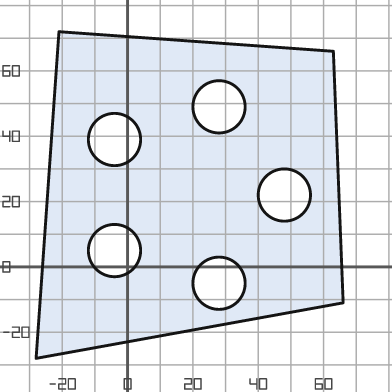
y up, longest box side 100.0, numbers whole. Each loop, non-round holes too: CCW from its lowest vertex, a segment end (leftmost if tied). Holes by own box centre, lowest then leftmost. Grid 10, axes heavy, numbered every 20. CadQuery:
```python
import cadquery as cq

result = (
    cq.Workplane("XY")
    .moveTo(-28.0, -28.0)
    .lineTo(66.0, -11.0)
    .lineTo(63.0, 66.0)
    .lineTo(-21.0, 72.0)
    .close()
    .moveTo(28.0, -5.0)
    .circle(8.0)
    .moveTo(-4.0, 5.0)
    .circle(8.0)
    .moveTo(48.0, 22.0)
    .circle(8.0)
    .moveTo(-4.0, 39.0)
    .circle(8.0)
    .moveTo(28.0, 49.0)
    .circle(8.0)
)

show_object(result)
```